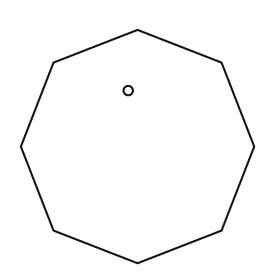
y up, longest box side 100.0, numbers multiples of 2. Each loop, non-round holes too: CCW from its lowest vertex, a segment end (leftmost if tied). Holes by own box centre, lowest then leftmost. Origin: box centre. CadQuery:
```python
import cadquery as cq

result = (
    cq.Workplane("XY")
    .moveTo(0.0, -50.0)
    .lineTo(36.0, -36.0)
    .lineTo(50.0, 0.0)
    .lineTo(36.0, 36.0)
    .lineTo(0.0, 50.0)
    .lineTo(-36.0, 36.0)
    .lineTo(-50.0, 0.0)
    .lineTo(-36.0, -36.0)
    .close()
    .moveTo(-4.0, 24.0)
    .circle(2.0)
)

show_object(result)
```